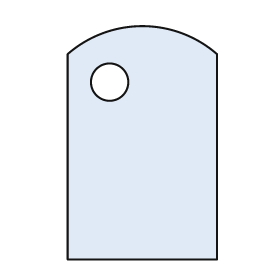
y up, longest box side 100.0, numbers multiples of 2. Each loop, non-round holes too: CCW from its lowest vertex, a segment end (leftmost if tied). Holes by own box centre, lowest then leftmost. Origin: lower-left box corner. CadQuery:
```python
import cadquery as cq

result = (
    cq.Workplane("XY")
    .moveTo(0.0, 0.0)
    .lineTo(64.0, 0.0)
    .lineTo(64.0, 88.0)
    .threePointArc((32.0, 100.0), (0.0, 88.0))
    .close()
    .moveTo(18.0, 76.0)
    .circle(8.0)
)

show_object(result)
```